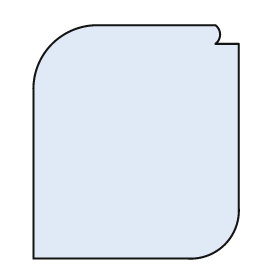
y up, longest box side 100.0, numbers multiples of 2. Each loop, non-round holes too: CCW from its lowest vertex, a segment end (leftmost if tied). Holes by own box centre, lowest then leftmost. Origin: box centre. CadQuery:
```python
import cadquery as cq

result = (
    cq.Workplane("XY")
    .moveTo(-44.0, -50.0)
    .lineTo(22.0, -50.0)
    .threePointArc((38.0, -44.0), (44.0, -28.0))
    .lineTo(44.0, 42.0)
    .lineTo(34.0, 42.0)
    .threePointArc((36.0, 46.0), (34.0, 50.0))
    .lineTo(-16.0, 50.0)
    .threePointArc((-36.0, 42.0), (-44.0, 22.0))
    .close()
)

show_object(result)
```